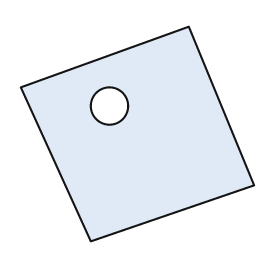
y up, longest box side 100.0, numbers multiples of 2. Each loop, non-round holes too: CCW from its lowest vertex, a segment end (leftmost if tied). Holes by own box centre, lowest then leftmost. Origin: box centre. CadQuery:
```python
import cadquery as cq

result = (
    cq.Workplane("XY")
    .moveTo(-20.0, -46.0)
    .lineTo(50.0, -22.0)
    .lineTo(22.0, 46.0)
    .lineTo(-50.0, 20.0)
    .close()
    .moveTo(-12.0, 12.0)
    .circle(8.0)
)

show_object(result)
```